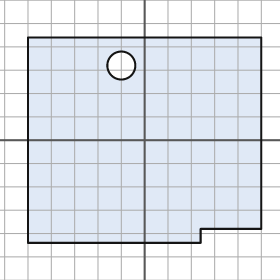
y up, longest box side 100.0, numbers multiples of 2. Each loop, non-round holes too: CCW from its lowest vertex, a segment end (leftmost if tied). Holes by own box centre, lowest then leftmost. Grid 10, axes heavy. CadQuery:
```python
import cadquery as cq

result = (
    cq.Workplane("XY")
    .moveTo(-50.0, -44.0)
    .lineTo(24.0, -44.0)
    .lineTo(24.0, -38.0)
    .lineTo(50.0, -38.0)
    .lineTo(50.0, 44.0)
    .lineTo(-50.0, 44.0)
    .close()
    .moveTo(-10.0, 32.0)
    .circle(6.0)
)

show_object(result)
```